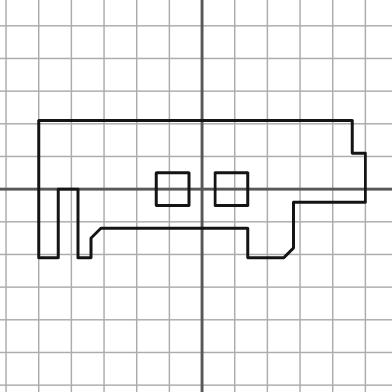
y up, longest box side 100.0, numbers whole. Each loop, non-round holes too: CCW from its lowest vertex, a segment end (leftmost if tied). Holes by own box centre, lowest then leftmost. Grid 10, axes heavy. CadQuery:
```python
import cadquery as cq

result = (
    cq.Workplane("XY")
    .moveTo(-50.0, -21.0)
    .lineTo(-44.0, -21.0)
    .lineTo(-44.0, 0.0)
    .lineTo(-38.0, 0.0)
    .lineTo(-38.0, -21.0)
    .lineTo(-34.0, -21.0)
    .lineTo(-34.0, -15.0)
    .lineTo(-31.0, -12.0)
    .lineTo(14.0, -12.0)
    .lineTo(14.0, -21.0)
    .lineTo(25.0, -21.0)
    .lineTo(28.0, -18.0)
    .lineTo(28.0, -4.0)
    .lineTo(50.0, -4.0)
    .lineTo(50.0, 11.0)
    .lineTo(46.0, 11.0)
    .lineTo(46.0, 21.0)
    .lineTo(-50.0, 21.0)
    .close()
    .moveTo(-14.0, -5.0)
    .lineTo(-4.0, -5.0)
    .lineTo(-4.0, 5.0)
    .lineTo(-14.0, 5.0)
    .close()
    .moveTo(4.0, -5.0)
    .lineTo(14.0, -5.0)
    .lineTo(14.0, 5.0)
    .lineTo(4.0, 5.0)
    .close()
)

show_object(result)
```